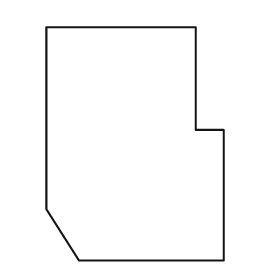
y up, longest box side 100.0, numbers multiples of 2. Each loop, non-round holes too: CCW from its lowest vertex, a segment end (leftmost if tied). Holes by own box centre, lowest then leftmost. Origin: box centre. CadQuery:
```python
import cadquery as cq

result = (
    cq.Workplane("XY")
    .moveTo(-24.0, -50.0)
    .lineTo(38.0, -50.0)
    .lineTo(38.0, 6.0)
    .lineTo(26.0, 6.0)
    .lineTo(26.0, 50.0)
    .lineTo(-38.0, 50.0)
    .lineTo(-38.0, -28.0)
    .close()
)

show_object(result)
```